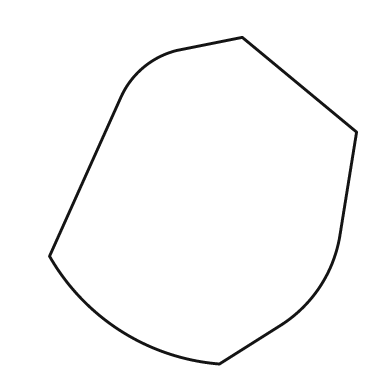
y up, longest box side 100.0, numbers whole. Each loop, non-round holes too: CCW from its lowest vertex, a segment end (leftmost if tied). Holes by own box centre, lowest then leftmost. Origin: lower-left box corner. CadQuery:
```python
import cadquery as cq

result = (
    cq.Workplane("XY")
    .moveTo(52.0, 0.0)
    .lineTo(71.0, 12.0)
    .threePointArc((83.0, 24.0), (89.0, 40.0))
    .lineTo(94.0, 71.0)
    .lineTo(59.0, 100.0)
    .lineTo(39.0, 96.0)
    .threePointArc((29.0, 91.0), (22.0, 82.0))
    .lineTo(0.0, 33.0)
    .threePointArc((22.0, 10.0), (52.0, 0.0))
    .close()
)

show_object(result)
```